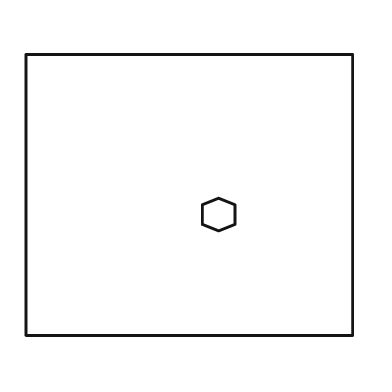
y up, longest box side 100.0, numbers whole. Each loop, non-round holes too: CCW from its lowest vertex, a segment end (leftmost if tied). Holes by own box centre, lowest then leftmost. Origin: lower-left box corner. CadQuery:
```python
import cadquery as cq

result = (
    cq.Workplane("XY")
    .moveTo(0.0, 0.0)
    .lineTo(100.0, 0.0)
    .lineTo(100.0, 86.0)
    .lineTo(0.0, 86.0)
    .close()
    .moveTo(59.0, 32.0)
    .lineTo(64.0, 34.0)
    .lineTo(64.0, 40.0)
    .lineTo(59.0, 42.0)
    .lineTo(54.0, 40.0)
    .lineTo(54.0, 34.0)
    .close()
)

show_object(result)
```